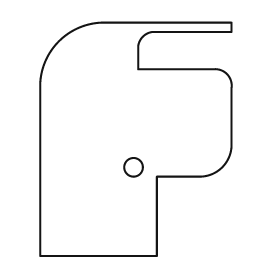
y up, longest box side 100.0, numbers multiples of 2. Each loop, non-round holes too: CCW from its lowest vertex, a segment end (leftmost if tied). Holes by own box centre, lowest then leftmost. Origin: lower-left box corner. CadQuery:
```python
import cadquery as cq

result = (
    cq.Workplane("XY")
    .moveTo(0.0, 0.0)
    .lineTo(50.0, 0.0)
    .lineTo(50.0, 34.0)
    .lineTo(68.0, 34.0)
    .threePointArc((78.0, 38.0), (82.0, 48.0))
    .lineTo(82.0, 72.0)
    .threePointArc((80.0, 78.0), (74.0, 80.0))
    .lineTo(42.0, 80.0)
    .lineTo(42.0, 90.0)
    .threePointArc((44.0, 94.0), (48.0, 96.0))
    .lineTo(82.0, 96.0)
    .lineTo(82.0, 100.0)
    .lineTo(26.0, 100.0)
    .threePointArc((8.0, 92.0), (0.0, 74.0))
    .close()
    .moveTo(40.0, 38.0)
    .circle(4.0)
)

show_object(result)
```